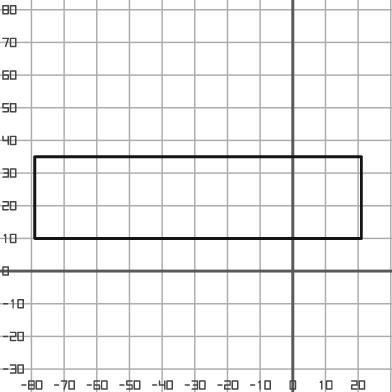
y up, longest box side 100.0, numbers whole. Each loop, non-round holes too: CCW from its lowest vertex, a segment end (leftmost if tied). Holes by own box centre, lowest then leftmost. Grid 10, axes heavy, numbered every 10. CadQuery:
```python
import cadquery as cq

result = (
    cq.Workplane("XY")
    .moveTo(-79.0, 10.0)
    .lineTo(21.0, 10.0)
    .lineTo(21.0, 35.0)
    .lineTo(-79.0, 35.0)
    .close()
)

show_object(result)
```